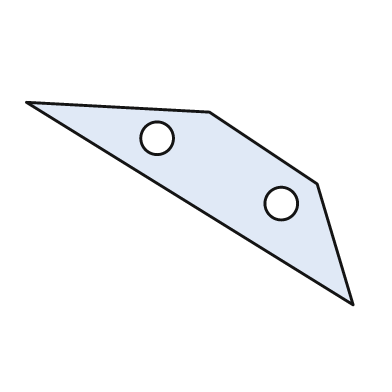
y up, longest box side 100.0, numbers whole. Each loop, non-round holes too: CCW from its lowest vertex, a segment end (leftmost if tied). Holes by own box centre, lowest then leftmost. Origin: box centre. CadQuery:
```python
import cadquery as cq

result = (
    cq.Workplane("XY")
    .moveTo(50.0, -31.0)
    .lineTo(39.0, 6.0)
    .lineTo(6.0, 28.0)
    .lineTo(-50.0, 31.0)
    .close()
    .moveTo(28.0, 0.0)
    .circle(5.0)
    .moveTo(-10.0, 20.0)
    .circle(5.0)
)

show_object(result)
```